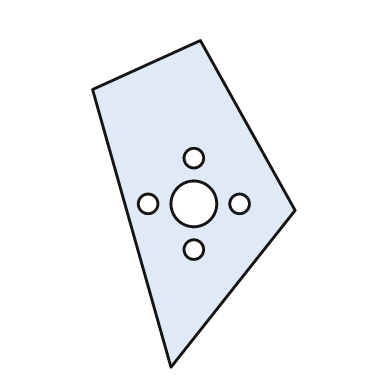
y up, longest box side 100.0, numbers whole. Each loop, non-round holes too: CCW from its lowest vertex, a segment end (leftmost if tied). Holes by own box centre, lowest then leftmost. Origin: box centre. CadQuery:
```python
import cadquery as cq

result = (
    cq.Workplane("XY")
    .moveTo(-7.0, -50.0)
    .lineTo(31.0, -2.0)
    .lineTo(2.0, 50.0)
    .lineTo(-31.0, 35.0)
    .close()
    .moveTo(0.0, -14.0)
    .circle(3.0)
    .moveTo(-14.0, 0.0)
    .circle(3.0)
    .moveTo(0.0, 0.0)
    .circle(7.0)
    .moveTo(14.0, 0.0)
    .circle(3.0)
    .moveTo(0.0, 14.0)
    .circle(3.0)
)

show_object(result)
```